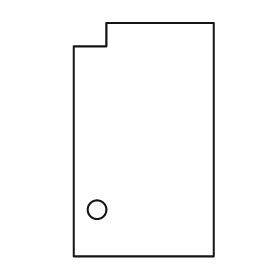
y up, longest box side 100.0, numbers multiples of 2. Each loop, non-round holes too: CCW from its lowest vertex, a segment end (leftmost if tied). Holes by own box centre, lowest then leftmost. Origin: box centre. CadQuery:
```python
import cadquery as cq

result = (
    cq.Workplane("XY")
    .moveTo(-30.0, -50.0)
    .lineTo(30.0, -50.0)
    .lineTo(30.0, 50.0)
    .lineTo(-16.0, 50.0)
    .lineTo(-16.0, 40.0)
    .lineTo(-30.0, 40.0)
    .close()
    .moveTo(-20.0, -30.0)
    .circle(4.0)
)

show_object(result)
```